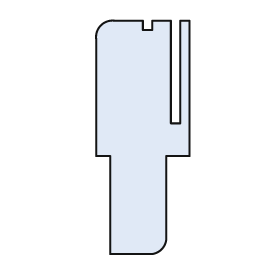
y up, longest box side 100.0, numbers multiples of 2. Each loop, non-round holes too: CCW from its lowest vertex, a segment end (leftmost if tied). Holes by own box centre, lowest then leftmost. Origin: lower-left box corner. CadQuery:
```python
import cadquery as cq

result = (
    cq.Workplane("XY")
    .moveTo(6.0, 0.0)
    .lineTo(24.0, 0.0)
    .threePointArc((28.0, 2.0), (30.0, 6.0))
    .lineTo(30.0, 42.0)
    .lineTo(40.0, 42.0)
    .lineTo(40.0, 100.0)
    .lineTo(36.0, 100.0)
    .lineTo(36.0, 56.0)
    .lineTo(32.0, 56.0)
    .lineTo(32.0, 100.0)
    .lineTo(24.0, 100.0)
    .lineTo(24.0, 96.0)
    .lineTo(20.0, 96.0)
    .lineTo(20.0, 100.0)
    .lineTo(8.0, 100.0)
    .threePointArc((2.0, 98.0), (0.0, 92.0))
    .lineTo(0.0, 42.0)
    .lineTo(6.0, 42.0)
    .close()
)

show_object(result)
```